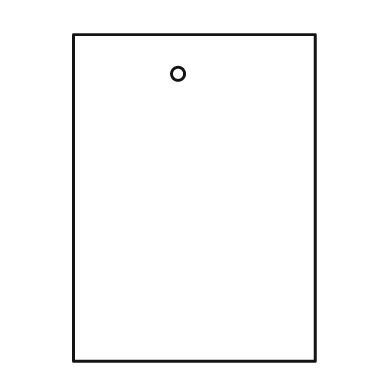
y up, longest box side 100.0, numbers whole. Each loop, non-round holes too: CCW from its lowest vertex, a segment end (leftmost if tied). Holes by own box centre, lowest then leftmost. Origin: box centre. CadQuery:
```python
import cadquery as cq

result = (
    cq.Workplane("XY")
    .moveTo(-37.0, -50.0)
    .lineTo(37.0, -50.0)
    .lineTo(37.0, 50.0)
    .lineTo(-37.0, 50.0)
    .close()
    .moveTo(-5.0, 38.0)
    .circle(2.0)
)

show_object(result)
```